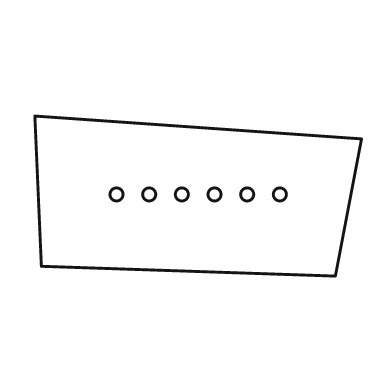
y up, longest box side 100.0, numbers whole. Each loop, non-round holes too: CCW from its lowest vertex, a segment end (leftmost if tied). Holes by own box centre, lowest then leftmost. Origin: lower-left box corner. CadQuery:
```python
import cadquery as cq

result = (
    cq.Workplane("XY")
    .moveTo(92.0, 0.0)
    .lineTo(100.0, 42.0)
    .lineTo(0.0, 49.0)
    .lineTo(2.0, 3.0)
    .close()
    .moveTo(25.0, 25.0)
    .circle(2.0)
    .moveTo(35.0, 25.0)
    .circle(2.0)
    .moveTo(45.0, 25.0)
    .circle(2.0)
    .moveTo(55.0, 25.0)
    .circle(2.0)
    .moveTo(65.0, 25.0)
    .circle(2.0)
    .moveTo(75.0, 25.0)
    .circle(2.0)
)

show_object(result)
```